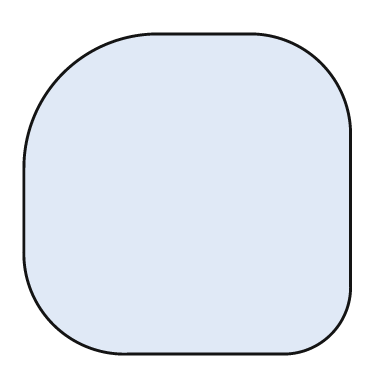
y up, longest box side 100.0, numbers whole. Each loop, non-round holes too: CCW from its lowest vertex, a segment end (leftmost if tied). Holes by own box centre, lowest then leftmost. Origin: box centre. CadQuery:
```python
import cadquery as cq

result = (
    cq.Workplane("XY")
    .moveTo(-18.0, -49.0)
    .lineTo(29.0, -49.0)
    .threePointArc((44.0, -43.0), (50.0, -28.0))
    .lineTo(50.0, 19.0)
    .threePointArc((41.0, 40.0), (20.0, 49.0))
    .lineTo(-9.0, 49.0)
    .threePointArc((-38.0, 37.0), (-50.0, 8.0))
    .lineTo(-50.0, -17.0)
    .threePointArc((-41.0, -40.0), (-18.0, -49.0))
    .close()
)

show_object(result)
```